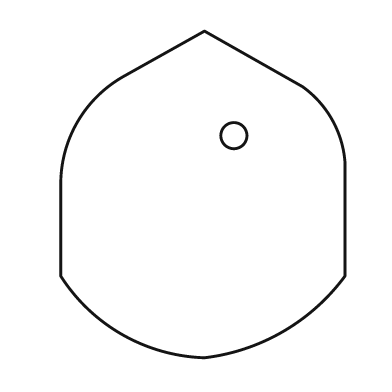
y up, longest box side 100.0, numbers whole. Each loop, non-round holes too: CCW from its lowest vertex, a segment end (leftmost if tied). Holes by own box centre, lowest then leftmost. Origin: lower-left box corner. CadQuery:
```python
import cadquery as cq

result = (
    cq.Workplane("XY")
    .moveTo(44.0, 0.0)
    .threePointArc((68.0, 8.0), (87.0, 25.0))
    .lineTo(87.0, 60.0)
    .threePointArc((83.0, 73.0), (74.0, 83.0))
    .lineTo(44.0, 100.0)
    .lineTo(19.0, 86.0)
    .threePointArc((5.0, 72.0), (0.0, 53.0))
    .lineTo(0.0, 25.0)
    .threePointArc((19.0, 7.0), (44.0, 0.0))
    .close()
    .moveTo(53.0, 68.0)
    .circle(4.0)
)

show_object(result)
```